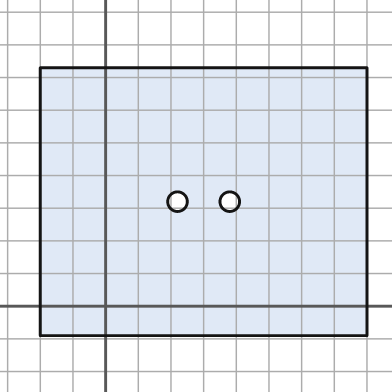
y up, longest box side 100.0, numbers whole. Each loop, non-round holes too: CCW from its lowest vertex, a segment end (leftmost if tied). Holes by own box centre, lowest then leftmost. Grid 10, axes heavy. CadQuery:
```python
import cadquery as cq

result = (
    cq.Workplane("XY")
    .moveTo(-20.0, -9.0)
    .lineTo(80.0, -9.0)
    .lineTo(80.0, 73.0)
    .lineTo(-20.0, 73.0)
    .close()
    .moveTo(22.0, 32.0)
    .circle(3.0)
    .moveTo(38.0, 32.0)
    .circle(3.0)
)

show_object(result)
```